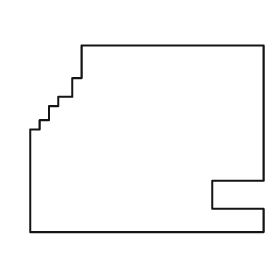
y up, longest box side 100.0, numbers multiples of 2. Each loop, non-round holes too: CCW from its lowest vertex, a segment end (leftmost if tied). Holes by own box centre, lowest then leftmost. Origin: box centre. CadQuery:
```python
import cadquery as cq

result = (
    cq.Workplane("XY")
    .moveTo(-50.0, -40.0)
    .lineTo(50.0, -40.0)
    .lineTo(50.0, -30.0)
    .lineTo(28.0, -30.0)
    .lineTo(28.0, -18.0)
    .lineTo(50.0, -18.0)
    .lineTo(50.0, 40.0)
    .lineTo(-28.0, 40.0)
    .lineTo(-28.0, 26.0)
    .lineTo(-32.0, 26.0)
    .lineTo(-32.0, 18.0)
    .lineTo(-38.0, 18.0)
    .lineTo(-38.0, 14.0)
    .lineTo(-42.0, 14.0)
    .lineTo(-42.0, 8.0)
    .lineTo(-46.0, 8.0)
    .lineTo(-46.0, 4.0)
    .lineTo(-50.0, 4.0)
    .close()
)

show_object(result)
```